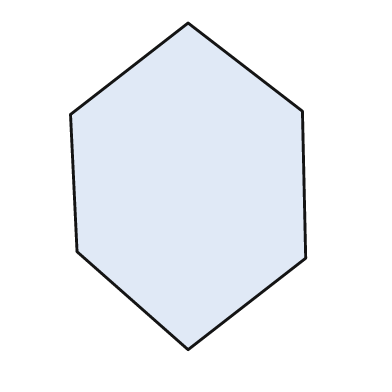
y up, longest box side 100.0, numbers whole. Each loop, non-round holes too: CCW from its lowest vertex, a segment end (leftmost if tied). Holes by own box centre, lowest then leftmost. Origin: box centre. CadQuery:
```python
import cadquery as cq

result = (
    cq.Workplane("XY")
    .moveTo(0.0, -50.0)
    .lineTo(36.0, -22.0)
    .lineTo(35.0, 23.0)
    .lineTo(0.0, 50.0)
    .lineTo(-36.0, 22.0)
    .lineTo(-34.0, -20.0)
    .close()
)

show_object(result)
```